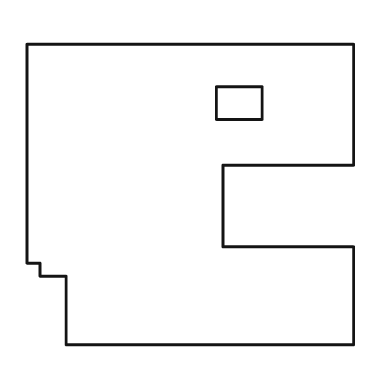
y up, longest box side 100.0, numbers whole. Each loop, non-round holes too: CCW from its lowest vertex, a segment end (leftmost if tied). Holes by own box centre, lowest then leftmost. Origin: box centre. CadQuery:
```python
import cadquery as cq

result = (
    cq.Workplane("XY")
    .moveTo(-38.0, -46.0)
    .lineTo(50.0, -46.0)
    .lineTo(50.0, -16.0)
    .lineTo(10.0, -16.0)
    .lineTo(10.0, 9.0)
    .lineTo(50.0, 9.0)
    .lineTo(50.0, 46.0)
    .lineTo(-50.0, 46.0)
    .lineTo(-50.0, -21.0)
    .lineTo(-46.0, -21.0)
    .lineTo(-46.0, -25.0)
    .lineTo(-38.0, -25.0)
    .close()
    .moveTo(8.0, 23.0)
    .lineTo(22.0, 23.0)
    .lineTo(22.0, 33.0)
    .lineTo(8.0, 33.0)
    .close()
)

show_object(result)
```